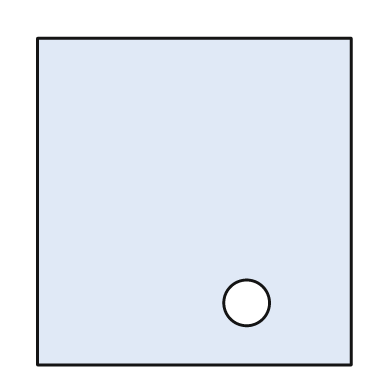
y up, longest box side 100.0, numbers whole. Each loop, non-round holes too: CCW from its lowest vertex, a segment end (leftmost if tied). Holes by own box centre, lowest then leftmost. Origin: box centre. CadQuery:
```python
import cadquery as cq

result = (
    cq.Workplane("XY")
    .moveTo(-48.0, -50.0)
    .lineTo(48.0, -50.0)
    .lineTo(48.0, 50.0)
    .lineTo(-48.0, 50.0)
    .close()
    .moveTo(16.0, -31.0)
    .circle(7.0)
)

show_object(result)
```